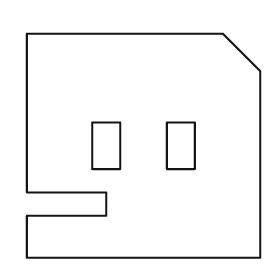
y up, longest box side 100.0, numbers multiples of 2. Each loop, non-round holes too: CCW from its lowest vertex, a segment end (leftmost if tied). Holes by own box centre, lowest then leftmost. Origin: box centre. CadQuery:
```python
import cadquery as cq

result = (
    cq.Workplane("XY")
    .moveTo(-50.0, -48.0)
    .lineTo(50.0, -48.0)
    .lineTo(50.0, 32.0)
    .lineTo(34.0, 48.0)
    .lineTo(-50.0, 48.0)
    .lineTo(-50.0, -20.0)
    .lineTo(-16.0, -20.0)
    .lineTo(-16.0, -30.0)
    .lineTo(-50.0, -30.0)
    .close()
    .moveTo(-22.0, -10.0)
    .lineTo(-10.0, -10.0)
    .lineTo(-10.0, 10.0)
    .lineTo(-22.0, 10.0)
    .close()
    .moveTo(10.0, -10.0)
    .lineTo(22.0, -10.0)
    .lineTo(22.0, 10.0)
    .lineTo(10.0, 10.0)
    .close()
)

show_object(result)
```